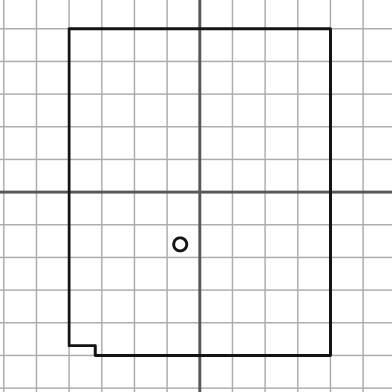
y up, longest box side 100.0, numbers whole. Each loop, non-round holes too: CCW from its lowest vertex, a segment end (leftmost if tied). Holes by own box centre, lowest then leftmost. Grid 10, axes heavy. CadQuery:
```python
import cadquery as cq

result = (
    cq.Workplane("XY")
    .moveTo(-32.0, -50.0)
    .lineTo(40.0, -50.0)
    .lineTo(40.0, 50.0)
    .lineTo(-40.0, 50.0)
    .lineTo(-40.0, -47.0)
    .lineTo(-32.0, -47.0)
    .close()
    .moveTo(-6.0, -16.0)
    .circle(2.0)
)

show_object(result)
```